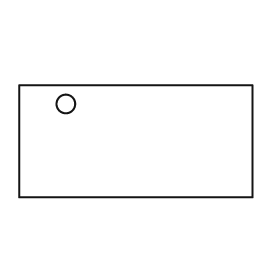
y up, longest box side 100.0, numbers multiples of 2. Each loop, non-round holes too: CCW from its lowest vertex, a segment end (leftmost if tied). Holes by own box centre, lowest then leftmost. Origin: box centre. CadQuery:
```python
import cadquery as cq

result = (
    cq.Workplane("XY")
    .moveTo(-50.0, -24.0)
    .lineTo(50.0, -24.0)
    .lineTo(50.0, 24.0)
    .lineTo(-50.0, 24.0)
    .close()
    .moveTo(-30.0, 16.0)
    .circle(4.0)
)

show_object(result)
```